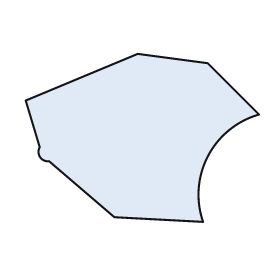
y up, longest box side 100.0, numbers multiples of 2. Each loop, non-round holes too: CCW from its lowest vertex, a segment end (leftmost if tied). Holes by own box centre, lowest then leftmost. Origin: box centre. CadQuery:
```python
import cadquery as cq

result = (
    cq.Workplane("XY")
    .moveTo(26.0, -36.0)
    .threePointArc((28.0, -8.0), (50.0, 10.0))
    .lineTo(28.0, 32.0)
    .lineTo(-2.0, 36.0)
    .lineTo(-50.0, 16.0)
    .lineTo(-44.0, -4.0)
    .threePointArc((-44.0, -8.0), (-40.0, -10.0))
    .lineTo(-12.0, -34.0)
    .close()
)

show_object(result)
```